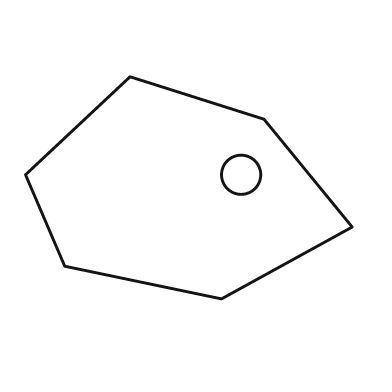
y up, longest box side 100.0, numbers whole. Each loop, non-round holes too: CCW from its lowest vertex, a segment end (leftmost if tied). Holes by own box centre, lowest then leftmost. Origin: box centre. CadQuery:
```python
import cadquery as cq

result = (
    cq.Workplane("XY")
    .moveTo(10.0, -34.0)
    .lineTo(50.0, -12.0)
    .lineTo(23.0, 21.0)
    .lineTo(-18.0, 34.0)
    .lineTo(-50.0, 4.0)
    .lineTo(-38.0, -24.0)
    .close()
    .moveTo(16.0, 4.0)
    .circle(6.0)
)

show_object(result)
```